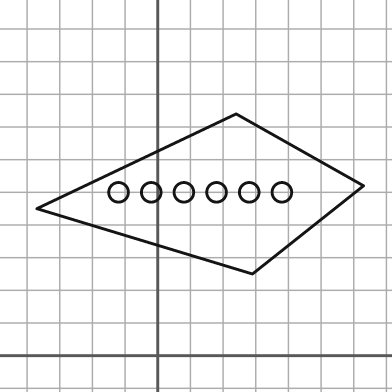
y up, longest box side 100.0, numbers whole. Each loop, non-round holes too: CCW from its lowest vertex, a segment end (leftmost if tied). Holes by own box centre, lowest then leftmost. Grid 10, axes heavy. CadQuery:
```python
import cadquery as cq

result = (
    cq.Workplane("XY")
    .moveTo(29.0, 25.0)
    .lineTo(63.0, 52.0)
    .lineTo(24.0, 74.0)
    .lineTo(-37.0, 45.0)
    .close()
    .moveTo(-12.0, 50.0)
    .circle(3.0)
    .moveTo(-2.0, 50.0)
    .circle(3.0)
    .moveTo(8.0, 50.0)
    .circle(3.0)
    .moveTo(18.0, 50.0)
    .circle(3.0)
    .moveTo(28.0, 50.0)
    .circle(3.0)
    .moveTo(38.0, 50.0)
    .circle(3.0)
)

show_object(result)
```